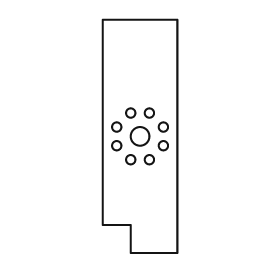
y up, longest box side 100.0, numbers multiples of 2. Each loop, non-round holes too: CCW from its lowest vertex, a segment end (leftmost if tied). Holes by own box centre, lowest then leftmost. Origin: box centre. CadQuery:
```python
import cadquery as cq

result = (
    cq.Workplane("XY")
    .moveTo(-4.0, -50.0)
    .lineTo(16.0, -50.0)
    .lineTo(16.0, 50.0)
    .lineTo(-16.0, 50.0)
    .lineTo(-16.0, -38.0)
    .lineTo(-4.0, -38.0)
    .close()
    .moveTo(-4.0, -10.0)
    .circle(2.0)
    .moveTo(4.0, -10.0)
    .circle(2.0)
    .moveTo(-10.0, -4.0)
    .circle(2.0)
    .moveTo(10.0, -4.0)
    .circle(2.0)
    .moveTo(0.0, 0.0)
    .circle(4.0)
    .moveTo(-10.0, 4.0)
    .circle(2.0)
    .moveTo(10.0, 4.0)
    .circle(2.0)
    .moveTo(-4.0, 10.0)
    .circle(2.0)
    .moveTo(4.0, 10.0)
    .circle(2.0)
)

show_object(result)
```